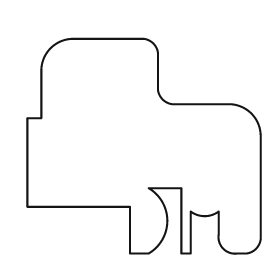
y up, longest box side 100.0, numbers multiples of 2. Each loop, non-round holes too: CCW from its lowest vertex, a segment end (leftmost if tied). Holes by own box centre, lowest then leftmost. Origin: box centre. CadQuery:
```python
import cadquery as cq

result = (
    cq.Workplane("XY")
    .moveTo(-6.0, -46.0)
    .lineTo(2.0, -46.0)
    .threePointArc((10.0, -32.0), (2.0, -18.0))
    .lineTo(16.0, -18.0)
    .lineTo(16.0, -46.0)
    .lineTo(20.0, -46.0)
    .lineTo(20.0, -28.0)
    .threePointArc((26.0, -30.0), (32.0, -28.0))
    .lineTo(32.0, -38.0)
    .threePointArc((34.0, -44.0), (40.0, -46.0))
    .lineTo(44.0, -46.0)
    .threePointArc((48.0, -44.0), (50.0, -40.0))
    .lineTo(50.0, 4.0)
    .threePointArc((46.0, 14.0), (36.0, 18.0))
    .lineTo(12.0, 18.0)
    .threePointArc((8.0, 20.0), (6.0, 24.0))
    .lineTo(6.0, 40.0)
    .threePointArc((4.0, 44.0), (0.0, 46.0))
    .lineTo(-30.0, 46.0)
    .threePointArc((-40.0, 42.0), (-44.0, 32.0))
    .lineTo(-44.0, 12.0)
    .lineTo(-50.0, 12.0)
    .lineTo(-50.0, -26.0)
    .lineTo(-6.0, -26.0)
    .close()
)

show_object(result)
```